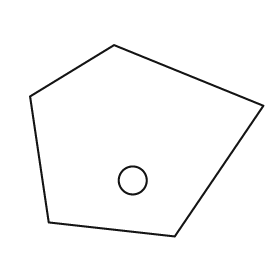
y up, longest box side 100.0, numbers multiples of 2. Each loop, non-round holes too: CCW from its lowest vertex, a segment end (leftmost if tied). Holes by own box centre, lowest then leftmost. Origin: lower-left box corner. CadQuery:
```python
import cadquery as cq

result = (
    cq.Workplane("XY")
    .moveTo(62.0, 0.0)
    .lineTo(100.0, 56.0)
    .lineTo(36.0, 82.0)
    .lineTo(0.0, 60.0)
    .lineTo(8.0, 6.0)
    .close()
    .moveTo(44.0, 24.0)
    .circle(6.0)
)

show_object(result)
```